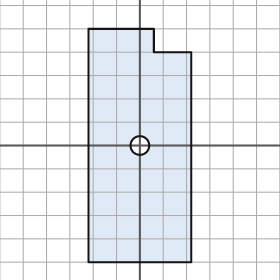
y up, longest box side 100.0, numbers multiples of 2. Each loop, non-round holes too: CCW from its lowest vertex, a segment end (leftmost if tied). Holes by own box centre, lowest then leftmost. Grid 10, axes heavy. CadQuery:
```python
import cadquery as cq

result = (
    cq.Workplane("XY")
    .moveTo(-22.0, -50.0)
    .lineTo(22.0, -50.0)
    .lineTo(22.0, 40.0)
    .lineTo(6.0, 40.0)
    .lineTo(6.0, 50.0)
    .lineTo(-22.0, 50.0)
    .close()
    .moveTo(0.0, 0.0)
    .circle(4.0)
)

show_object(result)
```